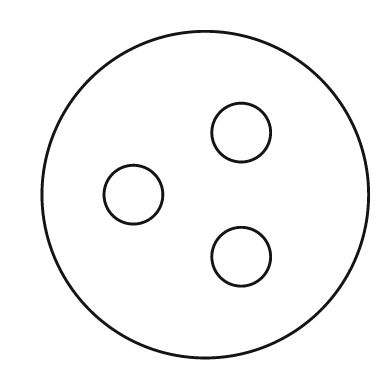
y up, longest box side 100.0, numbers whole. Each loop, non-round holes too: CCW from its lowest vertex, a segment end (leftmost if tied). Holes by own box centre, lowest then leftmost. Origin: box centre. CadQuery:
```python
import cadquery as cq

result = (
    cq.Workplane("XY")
    .moveTo(0.0, 0.0)
    .circle(50.0)
    .moveTo(11.0, -19.0)
    .circle(9.0)
    .moveTo(-22.0, 0.0)
    .circle(9.0)
    .moveTo(11.0, 19.0)
    .circle(9.0)
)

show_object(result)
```